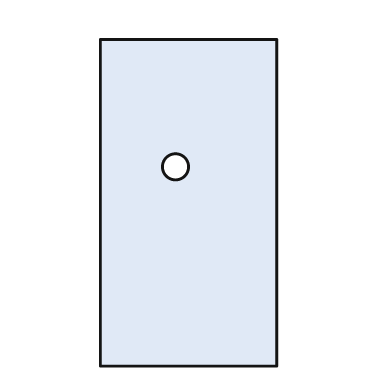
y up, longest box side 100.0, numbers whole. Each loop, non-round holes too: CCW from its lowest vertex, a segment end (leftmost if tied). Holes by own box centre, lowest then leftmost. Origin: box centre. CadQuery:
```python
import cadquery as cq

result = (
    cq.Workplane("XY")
    .moveTo(-27.0, -50.0)
    .lineTo(27.0, -50.0)
    .lineTo(27.0, 50.0)
    .lineTo(-27.0, 50.0)
    .close()
    .moveTo(-4.0, 11.0)
    .circle(4.0)
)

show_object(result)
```